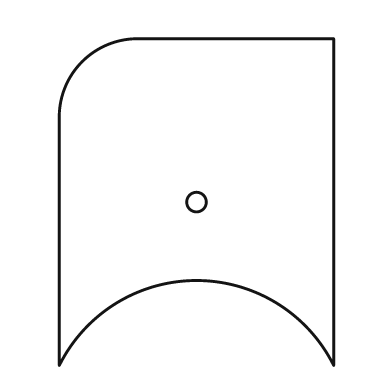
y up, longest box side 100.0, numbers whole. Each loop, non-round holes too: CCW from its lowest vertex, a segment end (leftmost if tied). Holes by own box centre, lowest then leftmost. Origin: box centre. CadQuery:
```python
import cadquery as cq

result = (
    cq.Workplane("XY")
    .moveTo(-42.0, -50.0)
    .threePointArc((0.0, -24.0), (42.0, -50.0))
    .lineTo(42.0, 50.0)
    .lineTo(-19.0, 50.0)
    .threePointArc((-35.0, 43.0), (-42.0, 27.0))
    .close()
    .moveTo(0.0, 0.0)
    .circle(3.0)
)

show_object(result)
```